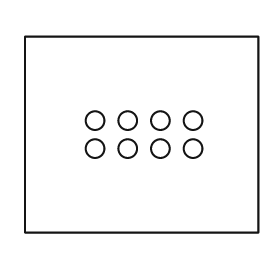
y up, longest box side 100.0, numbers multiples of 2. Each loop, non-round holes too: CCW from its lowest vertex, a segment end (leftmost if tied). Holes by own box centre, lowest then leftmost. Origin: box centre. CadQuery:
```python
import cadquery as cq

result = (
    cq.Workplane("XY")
    .moveTo(-50.0, -42.0)
    .lineTo(50.0, -42.0)
    .lineTo(50.0, 42.0)
    .lineTo(-50.0, 42.0)
    .close()
    .moveTo(-20.0, -6.0)
    .circle(4.0)
    .moveTo(-6.0, -6.0)
    .circle(4.0)
    .moveTo(8.0, -6.0)
    .circle(4.0)
    .moveTo(22.0, -6.0)
    .circle(4.0)
    .moveTo(-20.0, 6.0)
    .circle(4.0)
    .moveTo(-6.0, 6.0)
    .circle(4.0)
    .moveTo(8.0, 6.0)
    .circle(4.0)
    .moveTo(22.0, 6.0)
    .circle(4.0)
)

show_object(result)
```